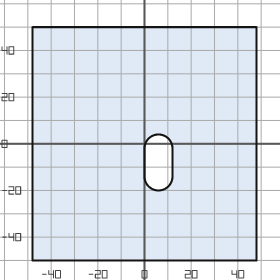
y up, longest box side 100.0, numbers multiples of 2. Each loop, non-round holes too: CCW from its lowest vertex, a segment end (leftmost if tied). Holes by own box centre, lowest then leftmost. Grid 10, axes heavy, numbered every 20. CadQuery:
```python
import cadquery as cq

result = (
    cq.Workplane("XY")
    .moveTo(-48.0, -50.0)
    .lineTo(48.0, -50.0)
    .lineTo(48.0, 50.0)
    .lineTo(-48.0, 50.0)
    .close()
    .moveTo(0.0, -14.0)
    .threePointArc((6.0, -20.0), (12.0, -14.0))
    .lineTo(12.0, -2.0)
    .threePointArc((6.0, 4.0), (0.0, -2.0))
    .close()
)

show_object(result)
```